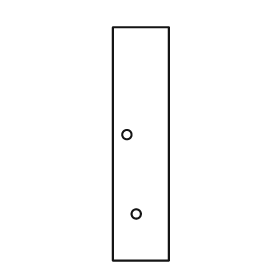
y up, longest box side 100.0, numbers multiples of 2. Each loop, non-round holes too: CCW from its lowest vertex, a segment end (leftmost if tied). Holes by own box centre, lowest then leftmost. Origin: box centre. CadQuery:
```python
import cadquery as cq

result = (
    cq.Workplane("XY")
    .moveTo(-12.0, -50.0)
    .lineTo(12.0, -50.0)
    .lineTo(12.0, 50.0)
    .lineTo(-12.0, 50.0)
    .close()
    .moveTo(-2.0, -30.0)
    .circle(2.0)
    .moveTo(-6.0, 4.0)
    .circle(2.0)
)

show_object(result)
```